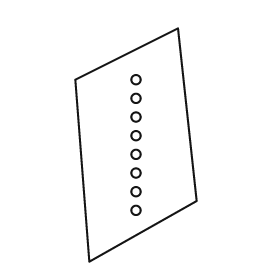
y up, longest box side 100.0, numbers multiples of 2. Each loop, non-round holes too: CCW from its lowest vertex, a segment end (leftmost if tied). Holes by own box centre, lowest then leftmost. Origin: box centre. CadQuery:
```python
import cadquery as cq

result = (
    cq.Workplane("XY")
    .moveTo(-20.0, -50.0)
    .lineTo(26.0, -24.0)
    .lineTo(18.0, 50.0)
    .lineTo(-26.0, 28.0)
    .close()
    .moveTo(0.0, -28.0)
    .circle(2.0)
    .moveTo(0.0, -20.0)
    .circle(2.0)
    .moveTo(0.0, -12.0)
    .circle(2.0)
    .moveTo(0.0, -4.0)
    .circle(2.0)
    .moveTo(0.0, 4.0)
    .circle(2.0)
    .moveTo(0.0, 12.0)
    .circle(2.0)
    .moveTo(0.0, 20.0)
    .circle(2.0)
    .moveTo(0.0, 28.0)
    .circle(2.0)
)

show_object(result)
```